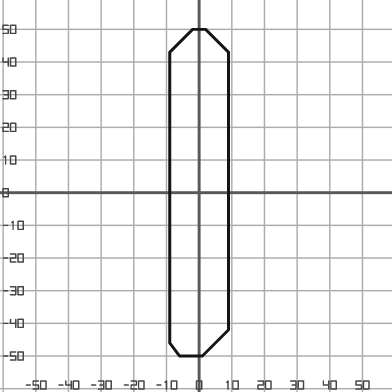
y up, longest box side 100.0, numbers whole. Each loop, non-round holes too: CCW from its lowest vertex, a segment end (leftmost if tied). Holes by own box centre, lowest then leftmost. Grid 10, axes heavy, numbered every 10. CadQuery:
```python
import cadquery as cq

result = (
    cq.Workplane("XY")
    .moveTo(-6.0, -50.0)
    .lineTo(1.0, -50.0)
    .lineTo(9.0, -42.0)
    .lineTo(9.0, 43.0)
    .lineTo(2.0, 50.0)
    .lineTo(-2.0, 50.0)
    .lineTo(-9.0, 43.0)
    .lineTo(-9.0, -46.0)
    .close()
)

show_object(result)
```